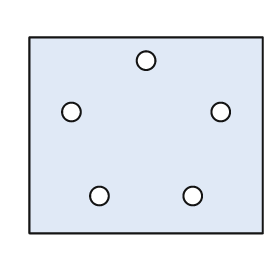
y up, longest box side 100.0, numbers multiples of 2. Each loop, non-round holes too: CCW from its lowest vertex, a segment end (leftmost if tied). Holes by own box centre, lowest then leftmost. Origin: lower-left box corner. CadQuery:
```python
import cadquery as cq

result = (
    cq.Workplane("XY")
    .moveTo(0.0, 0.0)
    .lineTo(100.0, 0.0)
    .lineTo(100.0, 84.0)
    .lineTo(0.0, 84.0)
    .close()
    .moveTo(30.0, 16.0)
    .circle(4.0)
    .moveTo(70.0, 16.0)
    .circle(4.0)
    .moveTo(18.0, 52.0)
    .circle(4.0)
    .moveTo(82.0, 52.0)
    .circle(4.0)
    .moveTo(50.0, 74.0)
    .circle(4.0)
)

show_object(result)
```